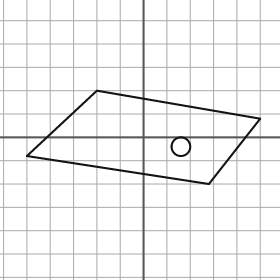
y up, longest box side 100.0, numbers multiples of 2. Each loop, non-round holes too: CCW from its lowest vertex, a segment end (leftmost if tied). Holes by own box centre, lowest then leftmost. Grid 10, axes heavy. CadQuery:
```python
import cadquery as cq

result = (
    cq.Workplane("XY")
    .moveTo(28.0, -20.0)
    .lineTo(50.0, 8.0)
    .lineTo(-20.0, 20.0)
    .lineTo(-50.0, -8.0)
    .close()
    .moveTo(16.0, -4.0)
    .circle(4.0)
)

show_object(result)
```